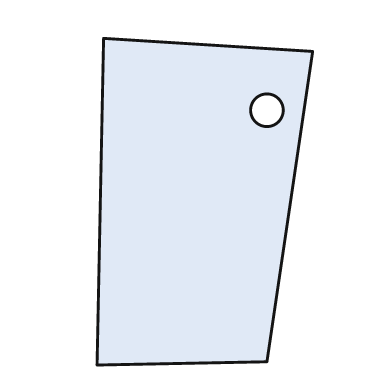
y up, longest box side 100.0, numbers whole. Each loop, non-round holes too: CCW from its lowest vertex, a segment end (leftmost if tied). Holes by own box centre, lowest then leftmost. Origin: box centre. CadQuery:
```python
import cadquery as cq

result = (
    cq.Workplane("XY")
    .moveTo(-33.0, -50.0)
    .lineTo(19.0, -49.0)
    .lineTo(33.0, 46.0)
    .lineTo(-31.0, 50.0)
    .close()
    .moveTo(19.0, 28.0)
    .circle(5.0)
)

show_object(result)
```